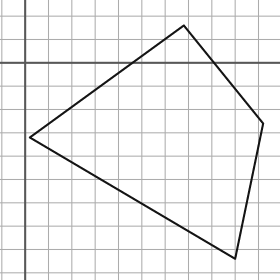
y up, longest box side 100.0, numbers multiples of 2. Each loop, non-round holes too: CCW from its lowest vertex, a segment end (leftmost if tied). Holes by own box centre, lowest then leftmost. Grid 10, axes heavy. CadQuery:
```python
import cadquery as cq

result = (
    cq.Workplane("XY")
    .moveTo(90.0, -84.0)
    .lineTo(102.0, -26.0)
    .lineTo(68.0, 16.0)
    .lineTo(2.0, -32.0)
    .close()
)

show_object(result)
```